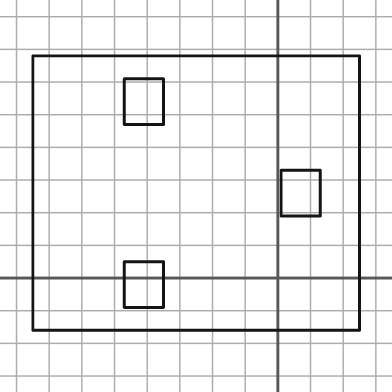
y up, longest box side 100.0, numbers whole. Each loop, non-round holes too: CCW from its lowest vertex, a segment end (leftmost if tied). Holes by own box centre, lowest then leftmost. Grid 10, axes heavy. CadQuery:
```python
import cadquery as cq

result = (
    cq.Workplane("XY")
    .moveTo(-75.0, -16.0)
    .lineTo(25.0, -16.0)
    .lineTo(25.0, 68.0)
    .lineTo(-75.0, 68.0)
    .close()
    .moveTo(-47.0, -9.0)
    .lineTo(-35.0, -9.0)
    .lineTo(-35.0, 5.0)
    .lineTo(-47.0, 5.0)
    .close()
    .moveTo(1.0, 19.0)
    .lineTo(13.0, 19.0)
    .lineTo(13.0, 33.0)
    .lineTo(1.0, 33.0)
    .close()
    .moveTo(-47.0, 47.0)
    .lineTo(-35.0, 47.0)
    .lineTo(-35.0, 61.0)
    .lineTo(-47.0, 61.0)
    .close()
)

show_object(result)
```